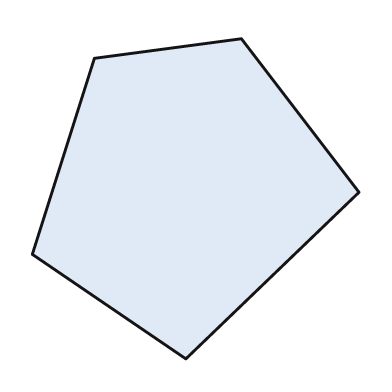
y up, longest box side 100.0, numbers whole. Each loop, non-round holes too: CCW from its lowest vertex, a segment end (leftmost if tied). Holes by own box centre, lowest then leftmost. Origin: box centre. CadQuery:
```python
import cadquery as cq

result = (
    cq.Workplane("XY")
    .moveTo(-3.0, -49.0)
    .lineTo(50.0, 2.0)
    .lineTo(14.0, 49.0)
    .lineTo(-31.0, 43.0)
    .lineTo(-50.0, -17.0)
    .close()
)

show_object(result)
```